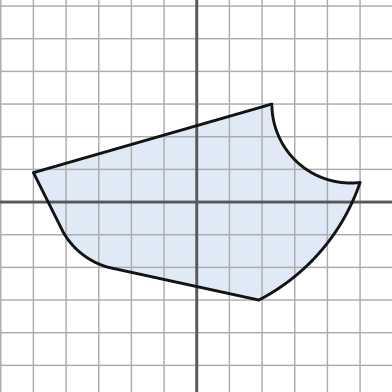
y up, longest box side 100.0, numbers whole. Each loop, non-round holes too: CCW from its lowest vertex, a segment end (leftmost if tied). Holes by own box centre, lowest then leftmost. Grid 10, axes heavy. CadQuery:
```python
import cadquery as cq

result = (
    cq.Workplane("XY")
    .moveTo(19.0, -30.0)
    .threePointArc((38.0, -15.0), (50.0, 6.0))
    .threePointArc((31.0, 12.0), (23.0, 30.0))
    .lineTo(-50.0, 9.0)
    .lineTo(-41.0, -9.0)
    .threePointArc((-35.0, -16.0), (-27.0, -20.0))
    .close()
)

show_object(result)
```